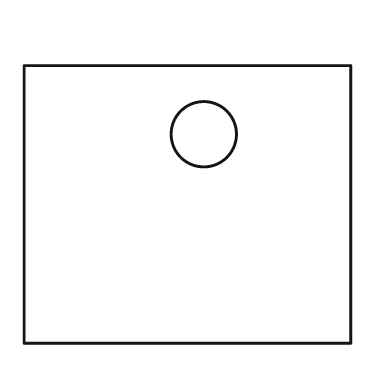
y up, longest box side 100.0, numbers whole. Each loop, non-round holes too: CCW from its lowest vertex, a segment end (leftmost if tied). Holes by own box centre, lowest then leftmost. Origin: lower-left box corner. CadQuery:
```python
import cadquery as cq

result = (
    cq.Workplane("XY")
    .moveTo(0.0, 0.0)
    .lineTo(100.0, 0.0)
    .lineTo(100.0, 85.0)
    .lineTo(0.0, 85.0)
    .close()
    .moveTo(55.0, 64.0)
    .circle(10.0)
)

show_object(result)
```